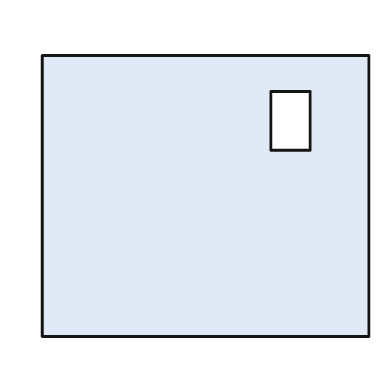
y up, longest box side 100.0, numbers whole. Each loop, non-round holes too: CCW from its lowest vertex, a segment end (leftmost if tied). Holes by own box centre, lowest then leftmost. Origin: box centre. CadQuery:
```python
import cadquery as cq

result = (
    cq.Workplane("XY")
    .moveTo(-50.0, -43.0)
    .lineTo(50.0, -43.0)
    .lineTo(50.0, 43.0)
    .lineTo(-50.0, 43.0)
    .close()
    .moveTo(20.0, 14.0)
    .lineTo(32.0, 14.0)
    .lineTo(32.0, 32.0)
    .lineTo(20.0, 32.0)
    .close()
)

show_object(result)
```